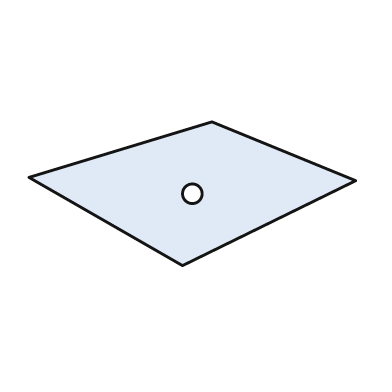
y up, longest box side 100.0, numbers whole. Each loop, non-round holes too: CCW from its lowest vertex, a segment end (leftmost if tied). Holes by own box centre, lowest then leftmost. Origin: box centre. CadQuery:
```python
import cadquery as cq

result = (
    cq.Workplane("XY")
    .moveTo(-3.0, -22.0)
    .lineTo(50.0, 4.0)
    .lineTo(6.0, 22.0)
    .lineTo(-50.0, 5.0)
    .close()
    .moveTo(0.0, 0.0)
    .circle(3.0)
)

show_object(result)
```